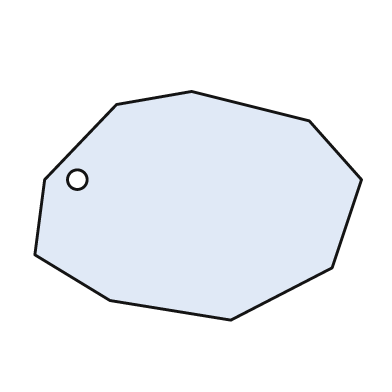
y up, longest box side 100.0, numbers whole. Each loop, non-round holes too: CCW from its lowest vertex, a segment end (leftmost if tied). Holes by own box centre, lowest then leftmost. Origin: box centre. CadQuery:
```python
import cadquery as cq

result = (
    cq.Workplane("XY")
    .moveTo(10.0, -35.0)
    .lineTo(41.0, -19.0)
    .lineTo(50.0, 8.0)
    .lineTo(34.0, 26.0)
    .lineTo(-2.0, 35.0)
    .lineTo(-25.0, 31.0)
    .lineTo(-47.0, 8.0)
    .lineTo(-50.0, -15.0)
    .lineTo(-27.0, -29.0)
    .close()
    .moveTo(-37.0, 8.0)
    .circle(3.0)
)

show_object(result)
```